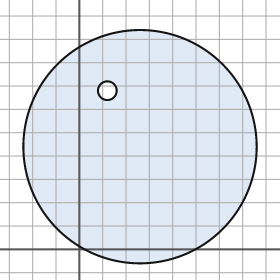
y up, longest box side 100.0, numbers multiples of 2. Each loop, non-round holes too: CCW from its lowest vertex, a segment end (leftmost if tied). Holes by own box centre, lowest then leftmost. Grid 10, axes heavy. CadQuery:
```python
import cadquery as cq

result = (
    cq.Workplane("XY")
    .moveTo(26.0, 44.0)
    .circle(50.0)
    .moveTo(12.0, 68.0)
    .circle(4.0)
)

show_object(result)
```